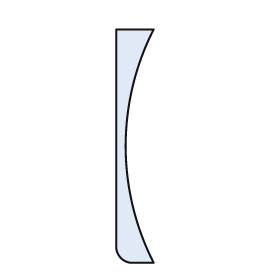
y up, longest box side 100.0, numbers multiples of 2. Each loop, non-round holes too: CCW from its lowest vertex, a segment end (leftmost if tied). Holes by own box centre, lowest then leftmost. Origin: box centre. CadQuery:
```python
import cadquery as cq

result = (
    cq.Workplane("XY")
    .moveTo(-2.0, -50.0)
    .lineTo(8.0, -50.0)
    .threePointArc((-4.0, 0.0), (8.0, 50.0))
    .lineTo(-8.0, 50.0)
    .lineTo(-8.0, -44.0)
    .threePointArc((-6.0, -48.0), (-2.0, -50.0))
    .close()
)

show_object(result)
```